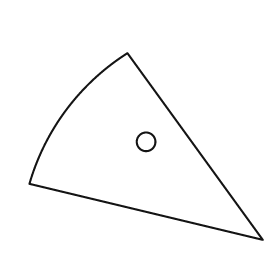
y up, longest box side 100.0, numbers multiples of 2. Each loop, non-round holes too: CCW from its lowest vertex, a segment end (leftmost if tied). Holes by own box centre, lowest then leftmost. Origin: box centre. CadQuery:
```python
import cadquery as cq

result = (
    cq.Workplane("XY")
    .moveTo(50.0, -40.0)
    .lineTo(-8.0, 40.0)
    .threePointArc((-34.0, 16.0), (-50.0, -16.0))
    .close()
    .moveTo(0.0, 2.0)
    .circle(4.0)
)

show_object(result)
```